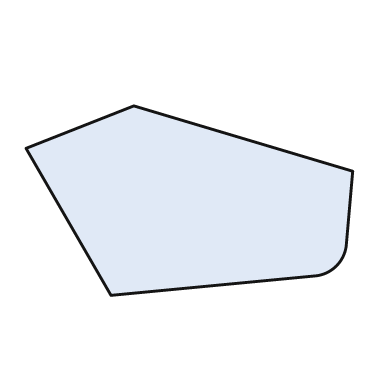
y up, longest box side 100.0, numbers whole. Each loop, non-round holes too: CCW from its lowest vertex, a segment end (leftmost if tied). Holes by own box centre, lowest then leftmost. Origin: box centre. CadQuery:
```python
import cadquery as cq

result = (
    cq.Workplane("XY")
    .moveTo(-24.0, -29.0)
    .lineTo(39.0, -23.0)
    .threePointArc((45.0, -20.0), (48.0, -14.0))
    .lineTo(50.0, 9.0)
    .lineTo(-17.0, 29.0)
    .lineTo(-50.0, 16.0)
    .close()
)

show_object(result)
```